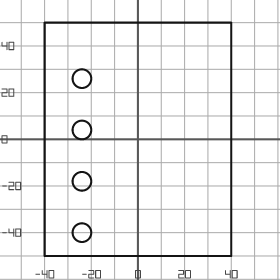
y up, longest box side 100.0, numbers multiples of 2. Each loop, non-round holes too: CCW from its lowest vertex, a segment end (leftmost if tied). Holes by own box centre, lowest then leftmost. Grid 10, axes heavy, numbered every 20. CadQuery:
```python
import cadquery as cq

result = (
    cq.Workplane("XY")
    .moveTo(-40.0, -50.0)
    .lineTo(40.0, -50.0)
    .lineTo(40.0, 50.0)
    .lineTo(-40.0, 50.0)
    .close()
    .moveTo(-24.0, -40.0)
    .circle(4.0)
    .moveTo(-24.0, -18.0)
    .circle(4.0)
    .moveTo(-24.0, 4.0)
    .circle(4.0)
    .moveTo(-24.0, 26.0)
    .circle(4.0)
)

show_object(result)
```